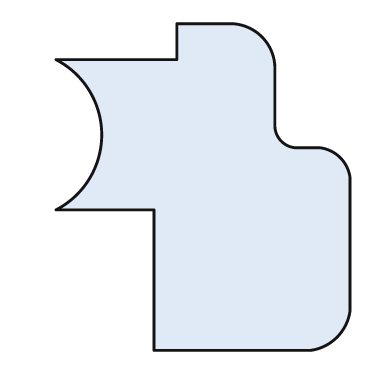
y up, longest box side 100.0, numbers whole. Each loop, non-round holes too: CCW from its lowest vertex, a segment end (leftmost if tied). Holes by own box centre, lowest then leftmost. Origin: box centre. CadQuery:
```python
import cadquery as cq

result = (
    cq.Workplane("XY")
    .moveTo(-15.0, -50.0)
    .lineTo(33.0, -50.0)
    .threePointArc((41.0, -46.0), (45.0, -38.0))
    .lineTo(45.0, 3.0)
    .threePointArc((42.0, 9.0), (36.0, 12.0))
    .lineTo(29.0, 12.0)
    .threePointArc((24.0, 14.0), (22.0, 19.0))
    .lineTo(22.0, 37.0)
    .threePointArc((18.0, 46.0), (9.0, 50.0))
    .lineTo(-8.0, 50.0)
    .lineTo(-8.0, 39.0)
    .lineTo(-45.0, 39.0)
    .threePointArc((-31.0, 16.0), (-45.0, -7.0))
    .lineTo(-15.0, -7.0)
    .close()
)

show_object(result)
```